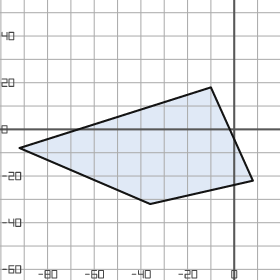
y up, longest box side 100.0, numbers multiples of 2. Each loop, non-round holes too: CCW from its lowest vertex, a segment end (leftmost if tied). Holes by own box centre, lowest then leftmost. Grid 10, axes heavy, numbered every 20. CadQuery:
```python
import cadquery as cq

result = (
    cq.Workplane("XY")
    .moveTo(-36.0, -32.0)
    .lineTo(8.0, -22.0)
    .lineTo(-10.0, 18.0)
    .lineTo(-92.0, -8.0)
    .close()
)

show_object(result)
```